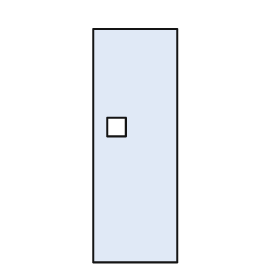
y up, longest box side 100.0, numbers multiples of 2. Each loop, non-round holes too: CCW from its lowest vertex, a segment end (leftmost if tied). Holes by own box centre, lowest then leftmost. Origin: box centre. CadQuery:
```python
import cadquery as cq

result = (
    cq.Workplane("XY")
    .moveTo(-18.0, -50.0)
    .lineTo(18.0, -50.0)
    .lineTo(18.0, 50.0)
    .lineTo(-18.0, 50.0)
    .close()
    .moveTo(-12.0, 4.0)
    .lineTo(-4.0, 4.0)
    .lineTo(-4.0, 12.0)
    .lineTo(-12.0, 12.0)
    .close()
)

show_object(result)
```